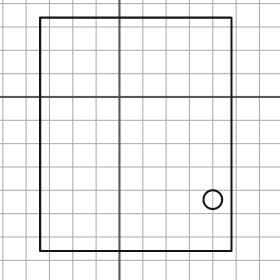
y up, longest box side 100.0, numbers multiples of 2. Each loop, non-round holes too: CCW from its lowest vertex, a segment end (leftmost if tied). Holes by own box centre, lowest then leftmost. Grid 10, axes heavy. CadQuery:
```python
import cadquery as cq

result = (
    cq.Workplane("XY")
    .moveTo(-34.0, -66.0)
    .lineTo(48.0, -66.0)
    .lineTo(48.0, 34.0)
    .lineTo(-34.0, 34.0)
    .close()
    .moveTo(40.0, -44.0)
    .circle(4.0)
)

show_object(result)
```